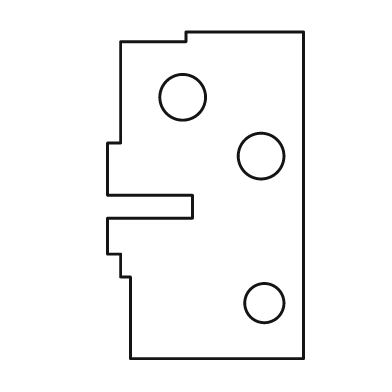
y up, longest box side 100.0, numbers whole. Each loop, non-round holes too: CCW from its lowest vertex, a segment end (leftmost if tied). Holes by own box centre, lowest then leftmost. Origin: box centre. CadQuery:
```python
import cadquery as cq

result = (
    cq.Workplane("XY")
    .moveTo(-23.0, -50.0)
    .lineTo(30.0, -50.0)
    .lineTo(30.0, 50.0)
    .lineTo(-6.0, 50.0)
    .lineTo(-6.0, 47.0)
    .lineTo(-26.0, 47.0)
    .lineTo(-26.0, 16.0)
    .lineTo(-30.0, 16.0)
    .lineTo(-30.0, 0.0)
    .lineTo(-4.0, 0.0)
    .lineTo(-4.0, -7.0)
    .lineTo(-30.0, -7.0)
    .lineTo(-30.0, -18.0)
    .lineTo(-26.0, -18.0)
    .lineTo(-26.0, -25.0)
    .lineTo(-23.0, -25.0)
    .close()
    .moveTo(18.0, -33.0)
    .circle(6.0)
    .moveTo(17.0, 12.0)
    .circle(7.0)
    .moveTo(-7.0, 30.0)
    .circle(7.0)
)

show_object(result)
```